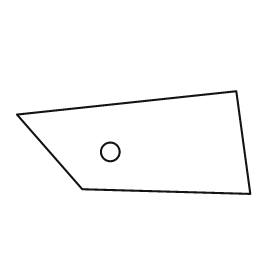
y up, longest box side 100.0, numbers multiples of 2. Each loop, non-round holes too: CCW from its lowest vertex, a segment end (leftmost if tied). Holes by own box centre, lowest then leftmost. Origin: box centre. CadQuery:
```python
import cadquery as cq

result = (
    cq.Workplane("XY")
    .moveTo(50.0, -22.0)
    .lineTo(44.0, 22.0)
    .lineTo(-50.0, 12.0)
    .lineTo(-22.0, -20.0)
    .close()
    .moveTo(-10.0, -4.0)
    .circle(4.0)
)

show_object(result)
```